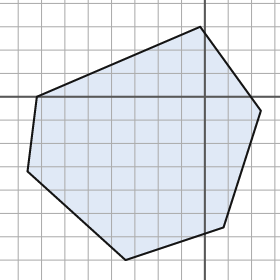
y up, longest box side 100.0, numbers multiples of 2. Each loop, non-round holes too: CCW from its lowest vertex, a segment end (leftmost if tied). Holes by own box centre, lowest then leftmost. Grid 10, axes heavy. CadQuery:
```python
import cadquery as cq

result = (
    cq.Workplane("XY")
    .moveTo(-34.0, -70.0)
    .lineTo(8.0, -56.0)
    .lineTo(24.0, -6.0)
    .lineTo(-2.0, 30.0)
    .lineTo(-72.0, 0.0)
    .lineTo(-76.0, -32.0)
    .close()
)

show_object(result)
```